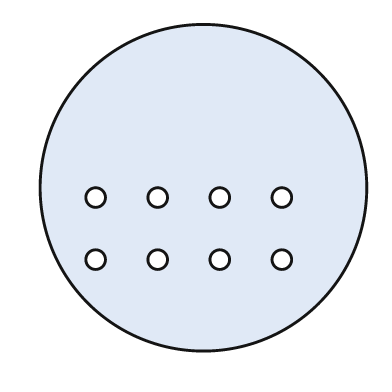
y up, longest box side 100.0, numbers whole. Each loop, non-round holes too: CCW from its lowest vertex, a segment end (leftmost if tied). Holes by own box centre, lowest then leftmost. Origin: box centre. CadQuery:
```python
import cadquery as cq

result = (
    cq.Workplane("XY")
    .moveTo(0.0, 0.0)
    .circle(50.0)
    .moveTo(-33.0, -22.0)
    .circle(3.0)
    .moveTo(-14.0, -22.0)
    .circle(3.0)
    .moveTo(5.0, -22.0)
    .circle(3.0)
    .moveTo(24.0, -22.0)
    .circle(3.0)
    .moveTo(-33.0, -3.0)
    .circle(3.0)
    .moveTo(-14.0, -3.0)
    .circle(3.0)
    .moveTo(5.0, -3.0)
    .circle(3.0)
    .moveTo(24.0, -3.0)
    .circle(3.0)
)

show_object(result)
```